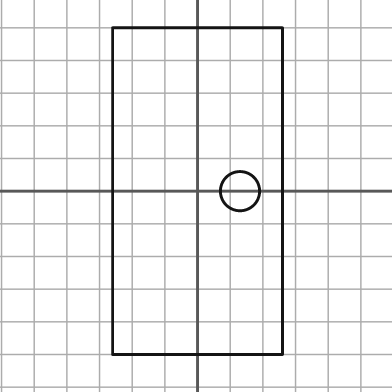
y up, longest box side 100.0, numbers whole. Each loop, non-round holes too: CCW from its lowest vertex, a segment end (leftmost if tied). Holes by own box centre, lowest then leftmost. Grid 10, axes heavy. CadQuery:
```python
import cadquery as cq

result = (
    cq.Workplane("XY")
    .moveTo(-26.0, -50.0)
    .lineTo(26.0, -50.0)
    .lineTo(26.0, 50.0)
    .lineTo(-26.0, 50.0)
    .close()
    .moveTo(13.0, 0.0)
    .circle(6.0)
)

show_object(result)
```